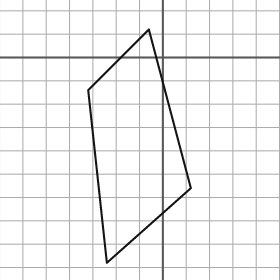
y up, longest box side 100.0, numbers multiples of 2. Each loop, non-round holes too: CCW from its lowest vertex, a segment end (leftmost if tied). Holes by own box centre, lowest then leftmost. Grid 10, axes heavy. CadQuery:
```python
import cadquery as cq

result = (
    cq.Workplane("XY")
    .moveTo(-24.0, -88.0)
    .lineTo(12.0, -56.0)
    .lineTo(-6.0, 12.0)
    .lineTo(-32.0, -14.0)
    .close()
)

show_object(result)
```